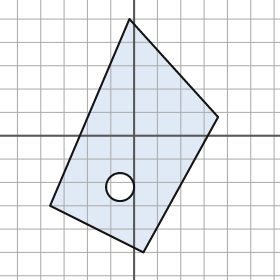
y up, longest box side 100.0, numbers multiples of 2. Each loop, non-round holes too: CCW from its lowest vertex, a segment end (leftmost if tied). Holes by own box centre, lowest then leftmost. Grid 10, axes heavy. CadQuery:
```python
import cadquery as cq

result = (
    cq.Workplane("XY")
    .moveTo(4.0, -50.0)
    .lineTo(36.0, 8.0)
    .lineTo(-2.0, 50.0)
    .lineTo(-36.0, -30.0)
    .close()
    .moveTo(-6.0, -22.0)
    .circle(6.0)
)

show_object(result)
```